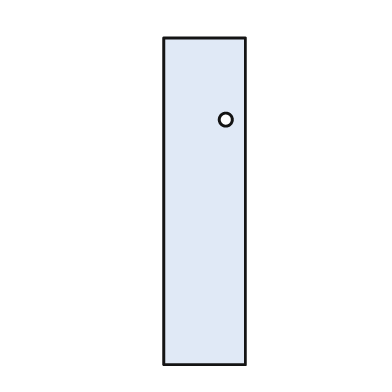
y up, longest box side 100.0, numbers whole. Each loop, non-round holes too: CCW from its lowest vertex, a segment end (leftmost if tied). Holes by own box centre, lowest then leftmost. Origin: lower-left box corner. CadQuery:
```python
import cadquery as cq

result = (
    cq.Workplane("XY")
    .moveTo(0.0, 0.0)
    .lineTo(25.0, 0.0)
    .lineTo(25.0, 100.0)
    .lineTo(0.0, 100.0)
    .close()
    .moveTo(19.0, 75.0)
    .circle(2.0)
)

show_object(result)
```